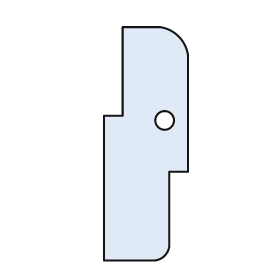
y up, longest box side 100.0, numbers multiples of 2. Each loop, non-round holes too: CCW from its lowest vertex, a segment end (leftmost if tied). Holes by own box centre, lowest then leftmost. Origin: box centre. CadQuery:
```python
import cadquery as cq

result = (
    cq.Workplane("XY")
    .moveTo(-18.0, -50.0)
    .lineTo(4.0, -50.0)
    .threePointArc((8.0, -48.0), (10.0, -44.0))
    .lineTo(10.0, -12.0)
    .lineTo(18.0, -12.0)
    .lineTo(18.0, 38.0)
    .threePointArc((14.0, 46.0), (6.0, 50.0))
    .lineTo(-10.0, 50.0)
    .lineTo(-10.0, 12.0)
    .lineTo(-18.0, 12.0)
    .close()
    .moveTo(8.0, 10.0)
    .circle(4.0)
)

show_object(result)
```